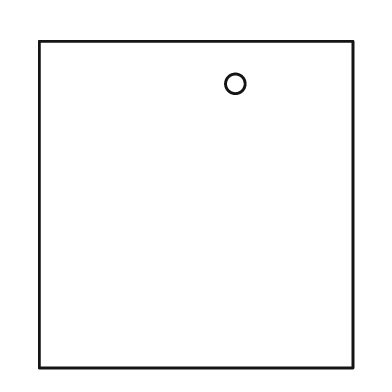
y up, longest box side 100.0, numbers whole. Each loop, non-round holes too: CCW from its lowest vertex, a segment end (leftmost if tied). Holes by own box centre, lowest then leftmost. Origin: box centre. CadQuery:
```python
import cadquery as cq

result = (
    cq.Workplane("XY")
    .moveTo(-48.0, -50.0)
    .lineTo(48.0, -50.0)
    .lineTo(48.0, 50.0)
    .lineTo(-48.0, 50.0)
    .close()
    .moveTo(12.0, 37.0)
    .circle(3.0)
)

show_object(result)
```